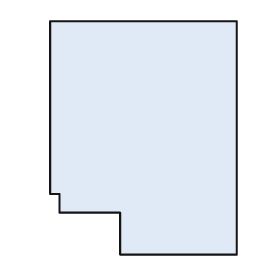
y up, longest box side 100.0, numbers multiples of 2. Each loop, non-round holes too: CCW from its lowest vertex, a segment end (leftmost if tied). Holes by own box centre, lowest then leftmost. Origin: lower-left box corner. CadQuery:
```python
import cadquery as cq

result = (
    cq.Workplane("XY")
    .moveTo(30.0, 0.0)
    .lineTo(80.0, 0.0)
    .lineTo(80.0, 100.0)
    .lineTo(0.0, 100.0)
    .lineTo(0.0, 26.0)
    .lineTo(4.0, 26.0)
    .lineTo(4.0, 18.0)
    .lineTo(30.0, 18.0)
    .close()
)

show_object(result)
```